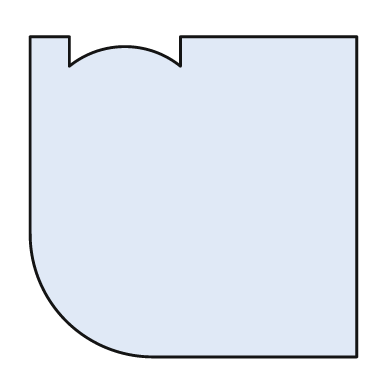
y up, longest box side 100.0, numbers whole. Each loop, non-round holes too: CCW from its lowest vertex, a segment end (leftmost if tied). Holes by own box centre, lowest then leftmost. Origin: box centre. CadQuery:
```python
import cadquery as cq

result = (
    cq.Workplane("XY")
    .moveTo(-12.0, -49.0)
    .lineTo(50.0, -49.0)
    .lineTo(50.0, 49.0)
    .lineTo(-4.0, 49.0)
    .lineTo(-4.0, 40.0)
    .threePointArc((-21.0, 46.0), (-38.0, 40.0))
    .lineTo(-38.0, 49.0)
    .lineTo(-50.0, 49.0)
    .lineTo(-50.0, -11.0)
    .threePointArc((-39.0, -38.0), (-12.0, -49.0))
    .close()
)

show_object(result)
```